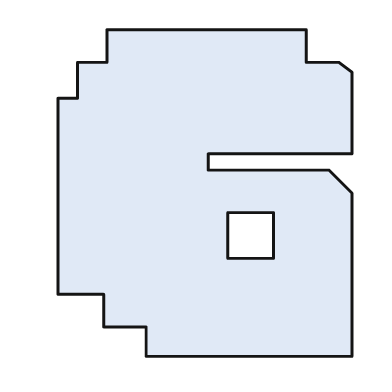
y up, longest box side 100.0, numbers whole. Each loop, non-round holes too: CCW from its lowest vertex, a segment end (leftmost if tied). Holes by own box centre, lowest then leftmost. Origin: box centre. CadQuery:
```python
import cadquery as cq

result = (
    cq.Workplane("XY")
    .moveTo(-18.0, -50.0)
    .lineTo(45.0, -50.0)
    .lineTo(45.0, 0.0)
    .lineTo(38.0, 7.0)
    .lineTo(1.0, 7.0)
    .lineTo(1.0, 12.0)
    .lineTo(45.0, 12.0)
    .lineTo(45.0, 37.0)
    .lineTo(41.0, 40.0)
    .lineTo(31.0, 40.0)
    .lineTo(31.0, 50.0)
    .lineTo(-30.0, 50.0)
    .lineTo(-30.0, 40.0)
    .lineTo(-39.0, 40.0)
    .lineTo(-39.0, 29.0)
    .lineTo(-45.0, 29.0)
    .lineTo(-45.0, -31.0)
    .lineTo(-31.0, -31.0)
    .lineTo(-31.0, -41.0)
    .lineTo(-18.0, -41.0)
    .close()
    .moveTo(7.0, -20.0)
    .lineTo(21.0, -20.0)
    .lineTo(21.0, -6.0)
    .lineTo(7.0, -6.0)
    .close()
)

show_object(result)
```